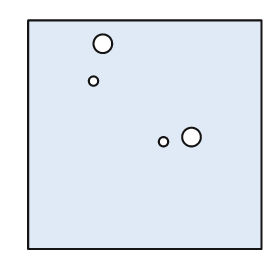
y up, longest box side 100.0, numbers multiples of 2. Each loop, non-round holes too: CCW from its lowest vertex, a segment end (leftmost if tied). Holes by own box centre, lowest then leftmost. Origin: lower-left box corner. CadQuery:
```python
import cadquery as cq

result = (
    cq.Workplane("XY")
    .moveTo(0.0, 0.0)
    .lineTo(100.0, 0.0)
    .lineTo(100.0, 98.0)
    .lineTo(0.0, 98.0)
    .close()
    .moveTo(58.0, 46.0)
    .circle(2.0)
    .moveTo(70.0, 48.0)
    .circle(4.0)
    .moveTo(28.0, 72.0)
    .circle(2.0)
    .moveTo(32.0, 88.0)
    .circle(4.0)
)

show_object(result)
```